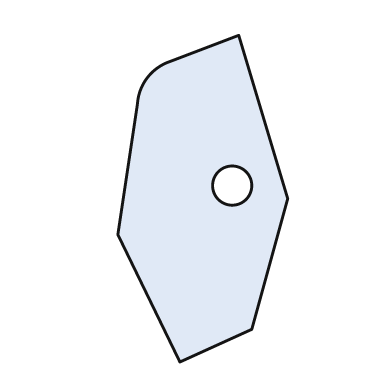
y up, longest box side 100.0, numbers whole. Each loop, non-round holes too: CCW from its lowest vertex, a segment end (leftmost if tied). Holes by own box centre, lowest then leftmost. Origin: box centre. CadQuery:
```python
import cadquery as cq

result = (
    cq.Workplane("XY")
    .moveTo(-7.0, -50.0)
    .lineTo(15.0, -40.0)
    .lineTo(26.0, 0.0)
    .lineTo(11.0, 50.0)
    .lineTo(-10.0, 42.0)
    .threePointArc((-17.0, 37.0), (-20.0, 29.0))
    .lineTo(-26.0, -11.0)
    .close()
    .moveTo(9.0, 4.0)
    .circle(6.0)
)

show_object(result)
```